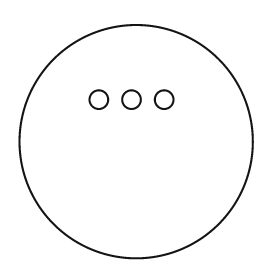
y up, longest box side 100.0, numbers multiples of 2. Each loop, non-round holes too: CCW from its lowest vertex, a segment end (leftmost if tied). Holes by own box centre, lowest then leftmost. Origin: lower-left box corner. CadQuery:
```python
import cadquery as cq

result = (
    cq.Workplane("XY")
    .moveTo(50.0, 50.0)
    .circle(50.0)
    .moveTo(34.0, 68.0)
    .circle(4.0)
    .moveTo(48.0, 68.0)
    .circle(4.0)
    .moveTo(62.0, 68.0)
    .circle(4.0)
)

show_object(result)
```